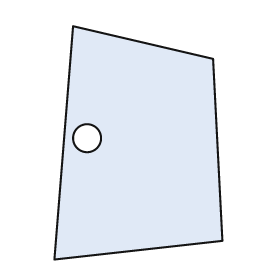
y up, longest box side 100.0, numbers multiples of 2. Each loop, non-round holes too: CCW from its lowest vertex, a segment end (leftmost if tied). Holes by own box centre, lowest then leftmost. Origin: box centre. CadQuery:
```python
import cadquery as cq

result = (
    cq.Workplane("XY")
    .moveTo(-36.0, -50.0)
    .lineTo(36.0, -42.0)
    .lineTo(32.0, 36.0)
    .lineTo(-28.0, 50.0)
    .close()
    .moveTo(-22.0, 2.0)
    .circle(6.0)
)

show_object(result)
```